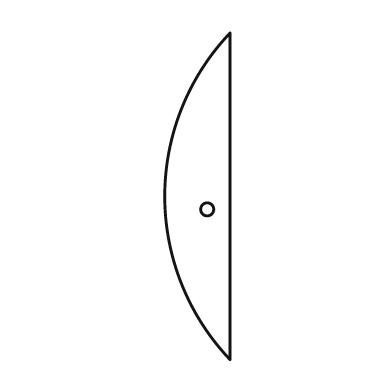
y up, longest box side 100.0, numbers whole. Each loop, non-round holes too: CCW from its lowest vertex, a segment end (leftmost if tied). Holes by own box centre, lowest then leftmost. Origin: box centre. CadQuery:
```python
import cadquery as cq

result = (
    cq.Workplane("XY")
    .moveTo(10.0, -50.0)
    .lineTo(10.0, 50.0)
    .threePointArc((-10.0, 0.0), (10.0, -50.0))
    .close()
    .moveTo(3.0, -4.0)
    .circle(2.0)
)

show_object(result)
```